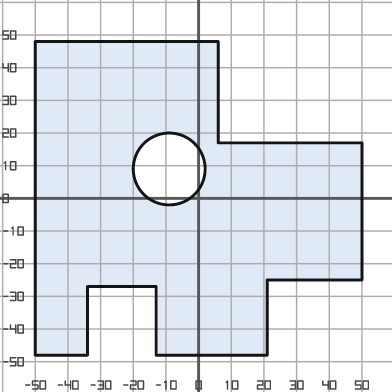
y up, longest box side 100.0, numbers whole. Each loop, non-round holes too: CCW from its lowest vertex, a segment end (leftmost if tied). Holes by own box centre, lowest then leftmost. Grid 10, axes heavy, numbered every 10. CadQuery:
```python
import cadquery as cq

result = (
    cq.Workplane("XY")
    .moveTo(-50.0, -48.0)
    .lineTo(-34.0, -48.0)
    .lineTo(-34.0, -27.0)
    .lineTo(-13.0, -27.0)
    .lineTo(-13.0, -48.0)
    .lineTo(21.0, -48.0)
    .lineTo(21.0, -25.0)
    .lineTo(50.0, -25.0)
    .lineTo(50.0, 17.0)
    .lineTo(6.0, 17.0)
    .lineTo(6.0, 48.0)
    .lineTo(-50.0, 48.0)
    .close()
    .moveTo(-9.0, 9.0)
    .circle(11.0)
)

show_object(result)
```